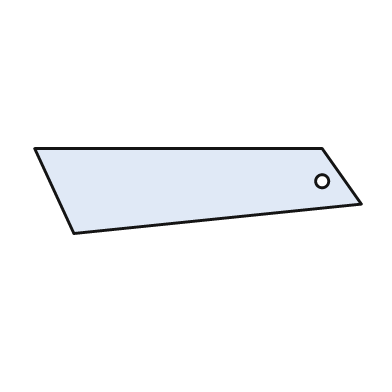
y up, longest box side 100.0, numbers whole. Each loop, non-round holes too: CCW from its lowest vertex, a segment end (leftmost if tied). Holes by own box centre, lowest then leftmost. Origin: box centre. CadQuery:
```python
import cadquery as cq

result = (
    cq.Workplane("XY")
    .moveTo(-38.0, -13.0)
    .lineTo(50.0, -4.0)
    .lineTo(38.0, 13.0)
    .lineTo(-50.0, 13.0)
    .close()
    .moveTo(38.0, 3.0)
    .circle(2.0)
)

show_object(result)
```